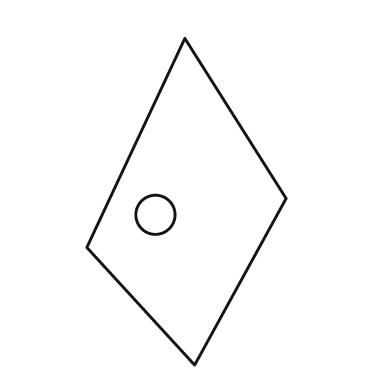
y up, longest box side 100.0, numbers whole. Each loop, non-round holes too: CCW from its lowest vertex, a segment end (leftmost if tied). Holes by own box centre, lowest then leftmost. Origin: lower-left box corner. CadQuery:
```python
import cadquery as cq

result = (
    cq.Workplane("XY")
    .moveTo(33.0, 0.0)
    .lineTo(61.0, 51.0)
    .lineTo(30.0, 100.0)
    .lineTo(0.0, 36.0)
    .close()
    .moveTo(21.0, 46.0)
    .circle(6.0)
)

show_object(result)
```